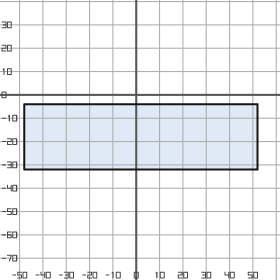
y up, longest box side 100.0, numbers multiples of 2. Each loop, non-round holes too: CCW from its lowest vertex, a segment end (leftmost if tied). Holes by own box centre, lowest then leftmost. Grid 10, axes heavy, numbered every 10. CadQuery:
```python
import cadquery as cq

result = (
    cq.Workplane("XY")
    .moveTo(-48.0, -32.0)
    .lineTo(52.0, -32.0)
    .lineTo(52.0, -4.0)
    .lineTo(-48.0, -4.0)
    .close()
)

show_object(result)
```